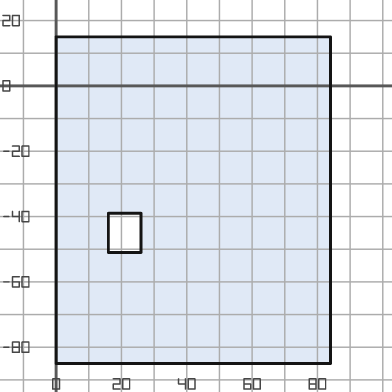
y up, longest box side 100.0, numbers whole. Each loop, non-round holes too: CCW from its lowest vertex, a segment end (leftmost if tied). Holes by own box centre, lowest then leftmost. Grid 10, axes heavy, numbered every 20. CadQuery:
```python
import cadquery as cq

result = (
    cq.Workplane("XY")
    .moveTo(0.0, -85.0)
    .lineTo(84.0, -85.0)
    .lineTo(84.0, 15.0)
    .lineTo(0.0, 15.0)
    .close()
    .moveTo(16.0, -51.0)
    .lineTo(26.0, -51.0)
    .lineTo(26.0, -39.0)
    .lineTo(16.0, -39.0)
    .close()
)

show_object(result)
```